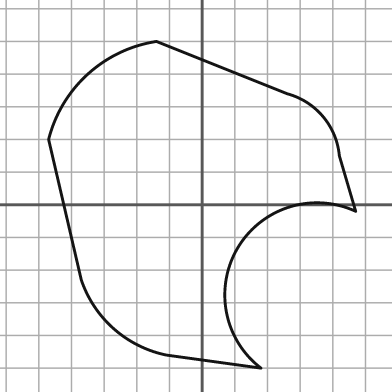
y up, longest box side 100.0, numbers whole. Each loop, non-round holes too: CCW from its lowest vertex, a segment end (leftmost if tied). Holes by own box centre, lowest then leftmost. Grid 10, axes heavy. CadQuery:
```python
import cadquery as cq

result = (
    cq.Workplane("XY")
    .moveTo(18.0, -50.0)
    .threePointArc((11.0, -13.0), (47.0, -2.0))
    .lineTo(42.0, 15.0)
    .threePointArc((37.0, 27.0), (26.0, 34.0))
    .lineTo(-14.0, 50.0)
    .threePointArc((-35.0, 40.0), (-47.0, 20.0))
    .lineTo(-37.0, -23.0)
    .threePointArc((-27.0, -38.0), (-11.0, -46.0))
    .close()
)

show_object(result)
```